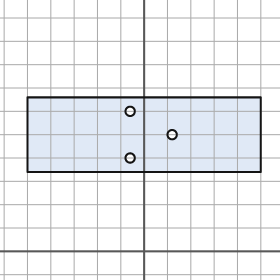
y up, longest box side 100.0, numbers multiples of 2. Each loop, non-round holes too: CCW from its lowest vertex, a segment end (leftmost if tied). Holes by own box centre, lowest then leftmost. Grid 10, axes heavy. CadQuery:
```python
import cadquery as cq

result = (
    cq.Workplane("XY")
    .moveTo(-50.0, 34.0)
    .lineTo(50.0, 34.0)
    .lineTo(50.0, 66.0)
    .lineTo(-50.0, 66.0)
    .close()
    .moveTo(-6.0, 40.0)
    .circle(2.0)
    .moveTo(12.0, 50.0)
    .circle(2.0)
    .moveTo(-6.0, 60.0)
    .circle(2.0)
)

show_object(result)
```